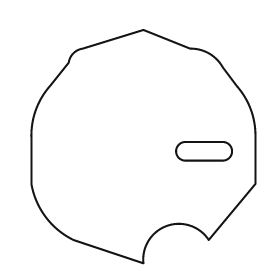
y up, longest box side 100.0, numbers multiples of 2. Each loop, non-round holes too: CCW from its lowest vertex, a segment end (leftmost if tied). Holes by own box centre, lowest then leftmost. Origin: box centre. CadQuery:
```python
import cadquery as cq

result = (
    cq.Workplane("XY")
    .moveTo(0.0, -50.0)
    .threePointArc((10.0, -34.0), (28.0, -40.0))
    .lineTo(48.0, -16.0)
    .lineTo(48.0, 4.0)
    .threePointArc((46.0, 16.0), (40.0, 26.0))
    .lineTo(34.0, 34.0)
    .threePointArc((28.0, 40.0), (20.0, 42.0))
    .lineTo(0.0, 50.0)
    .lineTo(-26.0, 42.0)
    .threePointArc((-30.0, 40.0), (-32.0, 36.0))
    .lineTo(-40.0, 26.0)
    .threePointArc((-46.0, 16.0), (-48.0, 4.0))
    .lineTo(-48.0, -16.0)
    .threePointArc((-42.0, -30.0), (-30.0, -40.0))
    .close()
    .moveTo(18.0, -6.0)
    .lineTo(34.0, -6.0)
    .threePointArc((38.0, -2.0), (34.0, 2.0))
    .lineTo(18.0, 2.0)
    .threePointArc((14.0, -2.0), (18.0, -6.0))
    .close()
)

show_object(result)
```